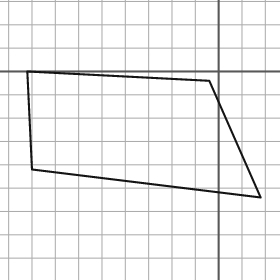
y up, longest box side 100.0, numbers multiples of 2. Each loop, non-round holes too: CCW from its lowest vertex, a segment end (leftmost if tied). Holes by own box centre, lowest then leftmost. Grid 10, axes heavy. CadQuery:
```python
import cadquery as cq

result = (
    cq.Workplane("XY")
    .moveTo(18.0, -54.0)
    .lineTo(-4.0, -4.0)
    .lineTo(-82.0, 0.0)
    .lineTo(-80.0, -42.0)
    .close()
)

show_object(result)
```